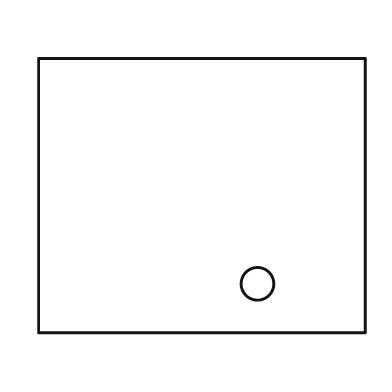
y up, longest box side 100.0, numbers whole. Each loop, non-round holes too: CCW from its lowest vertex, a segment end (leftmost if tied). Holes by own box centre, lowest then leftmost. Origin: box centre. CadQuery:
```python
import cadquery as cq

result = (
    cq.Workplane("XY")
    .moveTo(-50.0, -42.0)
    .lineTo(50.0, -42.0)
    .lineTo(50.0, 42.0)
    .lineTo(-50.0, 42.0)
    .close()
    .moveTo(17.0, -27.0)
    .circle(5.0)
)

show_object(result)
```